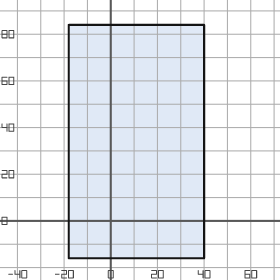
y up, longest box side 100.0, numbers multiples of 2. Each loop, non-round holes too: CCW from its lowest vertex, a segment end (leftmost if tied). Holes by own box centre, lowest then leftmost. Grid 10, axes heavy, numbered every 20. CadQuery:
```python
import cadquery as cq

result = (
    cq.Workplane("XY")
    .moveTo(-18.0, -16.0)
    .lineTo(40.0, -16.0)
    .lineTo(40.0, 84.0)
    .lineTo(-18.0, 84.0)
    .close()
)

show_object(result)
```